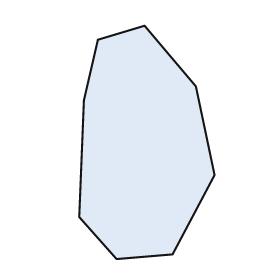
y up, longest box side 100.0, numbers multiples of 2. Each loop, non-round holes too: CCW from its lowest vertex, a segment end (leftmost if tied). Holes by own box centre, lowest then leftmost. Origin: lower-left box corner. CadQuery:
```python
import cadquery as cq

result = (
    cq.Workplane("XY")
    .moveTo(16.0, 0.0)
    .lineTo(40.0, 2.0)
    .lineTo(58.0, 36.0)
    .lineTo(50.0, 74.0)
    .lineTo(28.0, 100.0)
    .lineTo(8.0, 94.0)
    .lineTo(2.0, 68.0)
    .lineTo(0.0, 18.0)
    .close()
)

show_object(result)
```